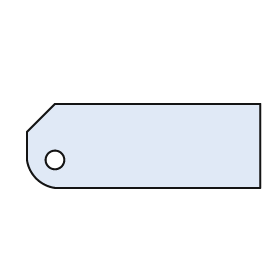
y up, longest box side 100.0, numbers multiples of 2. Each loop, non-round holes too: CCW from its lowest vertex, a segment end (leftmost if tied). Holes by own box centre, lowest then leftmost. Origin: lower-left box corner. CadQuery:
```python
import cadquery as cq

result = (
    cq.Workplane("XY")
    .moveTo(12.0, 0.0)
    .lineTo(100.0, 0.0)
    .lineTo(100.0, 36.0)
    .lineTo(12.0, 36.0)
    .lineTo(0.0, 24.0)
    .lineTo(0.0, 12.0)
    .threePointArc((4.0, 4.0), (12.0, 0.0))
    .close()
    .moveTo(12.0, 12.0)
    .circle(4.0)
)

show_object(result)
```